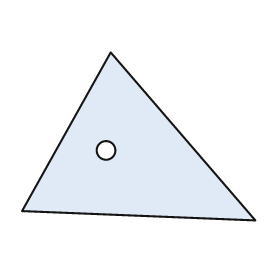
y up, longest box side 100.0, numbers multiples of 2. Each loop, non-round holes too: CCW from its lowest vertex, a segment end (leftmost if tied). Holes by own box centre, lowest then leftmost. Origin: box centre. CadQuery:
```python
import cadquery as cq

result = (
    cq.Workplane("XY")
    .moveTo(50.0, -36.0)
    .lineTo(-12.0, 36.0)
    .lineTo(-50.0, -32.0)
    .close()
    .moveTo(-14.0, -6.0)
    .circle(4.0)
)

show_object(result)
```